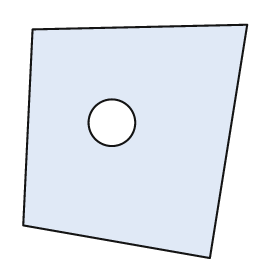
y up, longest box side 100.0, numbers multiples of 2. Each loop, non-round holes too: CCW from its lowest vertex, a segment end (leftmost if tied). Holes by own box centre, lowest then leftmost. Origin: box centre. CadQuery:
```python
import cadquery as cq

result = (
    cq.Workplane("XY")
    .moveTo(32.0, -50.0)
    .lineTo(48.0, 50.0)
    .lineTo(-44.0, 48.0)
    .lineTo(-48.0, -36.0)
    .close()
    .moveTo(-10.0, 8.0)
    .circle(10.0)
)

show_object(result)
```